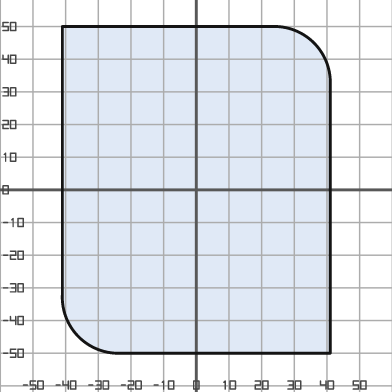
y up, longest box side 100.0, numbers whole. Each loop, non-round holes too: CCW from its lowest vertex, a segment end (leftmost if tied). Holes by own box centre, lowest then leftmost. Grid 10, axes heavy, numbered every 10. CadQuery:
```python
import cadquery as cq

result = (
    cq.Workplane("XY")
    .moveTo(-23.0, -50.0)
    .lineTo(41.0, -50.0)
    .lineTo(41.0, 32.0)
    .threePointArc((36.0, 45.0), (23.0, 50.0))
    .lineTo(-41.0, 50.0)
    .lineTo(-41.0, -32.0)
    .threePointArc((-36.0, -45.0), (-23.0, -50.0))
    .close()
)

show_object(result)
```